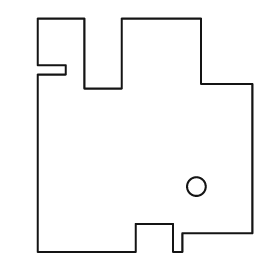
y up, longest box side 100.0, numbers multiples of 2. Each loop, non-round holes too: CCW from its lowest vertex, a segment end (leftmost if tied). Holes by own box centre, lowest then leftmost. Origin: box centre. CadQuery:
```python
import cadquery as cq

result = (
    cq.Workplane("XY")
    .moveTo(-46.0, -50.0)
    .lineTo(-4.0, -50.0)
    .lineTo(-4.0, -38.0)
    .lineTo(12.0, -38.0)
    .lineTo(12.0, -50.0)
    .lineTo(16.0, -50.0)
    .lineTo(16.0, -42.0)
    .lineTo(46.0, -42.0)
    .lineTo(46.0, 22.0)
    .lineTo(24.0, 22.0)
    .lineTo(24.0, 50.0)
    .lineTo(-10.0, 50.0)
    .lineTo(-10.0, 20.0)
    .lineTo(-26.0, 20.0)
    .lineTo(-26.0, 50.0)
    .lineTo(-46.0, 50.0)
    .lineTo(-46.0, 30.0)
    .lineTo(-34.0, 30.0)
    .lineTo(-34.0, 26.0)
    .lineTo(-46.0, 26.0)
    .close()
    .moveTo(22.0, -22.0)
    .circle(4.0)
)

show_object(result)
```